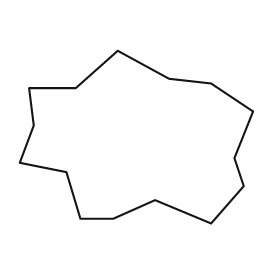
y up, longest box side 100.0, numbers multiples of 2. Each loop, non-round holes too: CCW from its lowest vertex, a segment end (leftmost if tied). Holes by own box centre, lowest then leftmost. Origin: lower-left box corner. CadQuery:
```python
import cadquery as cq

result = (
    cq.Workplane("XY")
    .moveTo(82.0, 0.0)
    .lineTo(96.0, 16.0)
    .lineTo(92.0, 28.0)
    .lineTo(100.0, 48.0)
    .lineTo(82.0, 60.0)
    .lineTo(64.0, 62.0)
    .lineTo(42.0, 74.0)
    .lineTo(24.0, 58.0)
    .lineTo(4.0, 58.0)
    .lineTo(6.0, 42.0)
    .lineTo(0.0, 26.0)
    .lineTo(20.0, 22.0)
    .lineTo(26.0, 2.0)
    .lineTo(40.0, 2.0)
    .lineTo(58.0, 10.0)
    .close()
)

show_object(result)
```